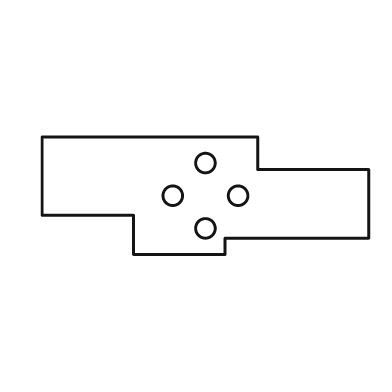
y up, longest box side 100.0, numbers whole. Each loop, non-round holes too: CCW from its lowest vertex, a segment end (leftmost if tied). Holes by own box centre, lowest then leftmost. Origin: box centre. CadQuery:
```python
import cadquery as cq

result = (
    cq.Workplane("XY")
    .moveTo(-22.0, -18.0)
    .lineTo(6.0, -18.0)
    .lineTo(6.0, -13.0)
    .lineTo(50.0, -13.0)
    .lineTo(50.0, 8.0)
    .lineTo(16.0, 8.0)
    .lineTo(16.0, 18.0)
    .lineTo(-50.0, 18.0)
    .lineTo(-50.0, -6.0)
    .lineTo(-22.0, -6.0)
    .close()
    .moveTo(0.0, -10.0)
    .circle(3.0)
    .moveTo(-10.0, 0.0)
    .circle(3.0)
    .moveTo(10.0, 0.0)
    .circle(3.0)
    .moveTo(0.0, 10.0)
    .circle(3.0)
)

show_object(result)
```